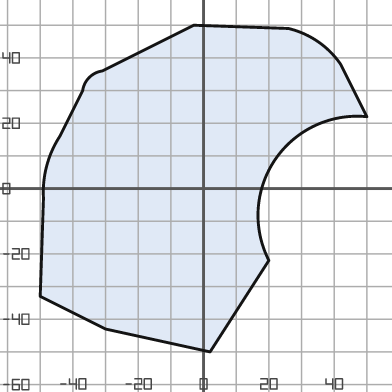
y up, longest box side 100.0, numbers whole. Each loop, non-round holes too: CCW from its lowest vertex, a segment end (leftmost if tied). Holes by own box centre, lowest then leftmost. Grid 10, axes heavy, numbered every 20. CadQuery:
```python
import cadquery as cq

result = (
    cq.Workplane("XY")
    .moveTo(2.0, -50.0)
    .lineTo(20.0, -22.0)
    .threePointArc((22.0, 9.0), (50.0, 22.0))
    .lineTo(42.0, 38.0)
    .threePointArc((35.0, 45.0), (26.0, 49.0))
    .lineTo(-3.0, 50.0)
    .lineTo(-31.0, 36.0)
    .threePointArc((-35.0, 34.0), (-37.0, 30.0))
    .lineTo(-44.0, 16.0)
    .threePointArc((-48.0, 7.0), (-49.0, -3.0))
    .lineTo(-50.0, -33.0)
    .lineTo(-30.0, -43.0)
    .close()
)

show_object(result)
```